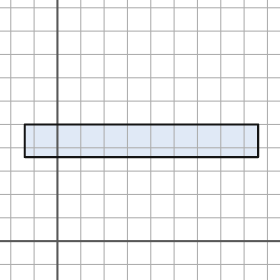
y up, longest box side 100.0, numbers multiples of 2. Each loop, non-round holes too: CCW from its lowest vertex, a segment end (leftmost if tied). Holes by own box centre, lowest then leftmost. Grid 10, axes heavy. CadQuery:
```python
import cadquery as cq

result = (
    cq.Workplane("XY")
    .moveTo(-14.0, 36.0)
    .lineTo(86.0, 36.0)
    .lineTo(86.0, 50.0)
    .lineTo(-14.0, 50.0)
    .close()
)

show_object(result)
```